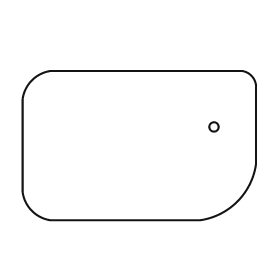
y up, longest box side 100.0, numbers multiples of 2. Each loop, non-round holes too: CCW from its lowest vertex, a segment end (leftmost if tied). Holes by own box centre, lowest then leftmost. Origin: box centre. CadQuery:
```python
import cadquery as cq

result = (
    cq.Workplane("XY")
    .moveTo(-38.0, -32.0)
    .lineTo(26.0, -32.0)
    .threePointArc((42.0, -24.0), (50.0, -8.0))
    .lineTo(50.0, 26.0)
    .threePointArc((48.0, 30.0), (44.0, 32.0))
    .lineTo(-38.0, 32.0)
    .threePointArc((-46.0, 28.0), (-50.0, 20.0))
    .lineTo(-50.0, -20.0)
    .threePointArc((-46.0, -28.0), (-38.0, -32.0))
    .close()
    .moveTo(32.0, 8.0)
    .circle(2.0)
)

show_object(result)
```